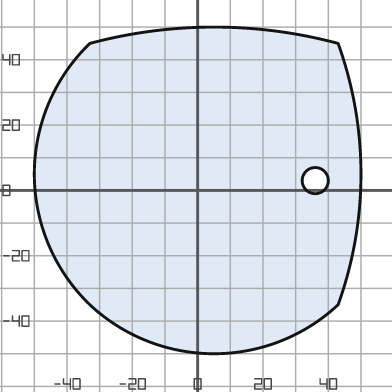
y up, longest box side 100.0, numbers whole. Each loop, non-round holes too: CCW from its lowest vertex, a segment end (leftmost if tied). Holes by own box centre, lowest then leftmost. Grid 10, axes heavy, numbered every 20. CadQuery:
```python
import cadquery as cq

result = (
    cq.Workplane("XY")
    .moveTo(-33.0, -35.0)
    .threePointArc((5.0, -50.0), (43.0, -35.0))
    .threePointArc((50.0, 5.0), (43.0, 45.0))
    .threePointArc((5.0, 50.0), (-33.0, 45.0))
    .threePointArc((-50.0, 5.0), (-33.0, -35.0))
    .close()
    .moveTo(36.0, 3.0)
    .circle(4.0)
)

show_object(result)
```